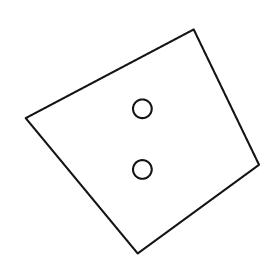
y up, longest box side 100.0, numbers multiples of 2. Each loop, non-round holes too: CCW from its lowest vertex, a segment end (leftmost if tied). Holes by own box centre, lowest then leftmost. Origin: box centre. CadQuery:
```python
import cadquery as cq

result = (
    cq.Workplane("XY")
    .moveTo(-2.0, -48.0)
    .lineTo(50.0, -10.0)
    .lineTo(22.0, 48.0)
    .lineTo(-50.0, 10.0)
    .close()
    .moveTo(0.0, -12.0)
    .circle(4.0)
    .moveTo(0.0, 14.0)
    .circle(4.0)
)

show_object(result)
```